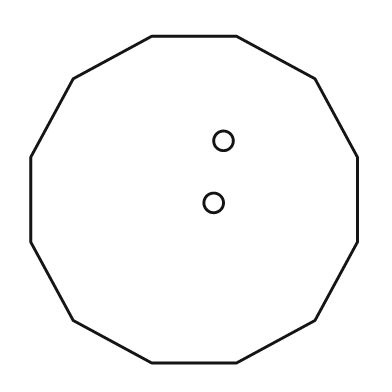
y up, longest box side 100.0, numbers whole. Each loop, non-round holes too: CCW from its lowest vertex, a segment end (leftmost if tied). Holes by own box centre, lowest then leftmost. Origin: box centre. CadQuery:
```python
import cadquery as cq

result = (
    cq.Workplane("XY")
    .moveTo(-13.0, -50.0)
    .lineTo(13.0, -50.0)
    .lineTo(37.0, -37.0)
    .lineTo(50.0, -13.0)
    .lineTo(50.0, 13.0)
    .lineTo(37.0, 37.0)
    .lineTo(13.0, 50.0)
    .lineTo(-13.0, 50.0)
    .lineTo(-37.0, 37.0)
    .lineTo(-50.0, 13.0)
    .lineTo(-50.0, -13.0)
    .lineTo(-37.0, -37.0)
    .close()
    .moveTo(6.0, -1.0)
    .circle(3.0)
    .moveTo(9.0, 18.0)
    .circle(3.0)
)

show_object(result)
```